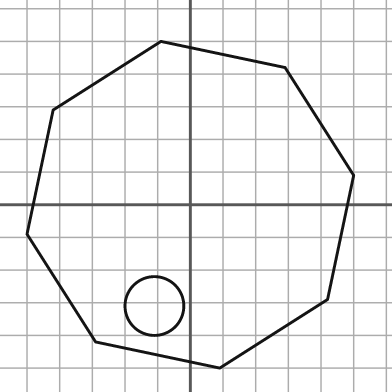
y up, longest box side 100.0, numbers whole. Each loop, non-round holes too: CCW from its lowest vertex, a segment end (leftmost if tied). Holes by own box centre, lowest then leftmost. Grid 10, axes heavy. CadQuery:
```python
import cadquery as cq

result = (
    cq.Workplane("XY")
    .moveTo(9.0, -50.0)
    .lineTo(42.0, -29.0)
    .lineTo(50.0, 9.0)
    .lineTo(29.0, 42.0)
    .lineTo(-9.0, 50.0)
    .lineTo(-42.0, 29.0)
    .lineTo(-50.0, -9.0)
    .lineTo(-29.0, -42.0)
    .close()
    .moveTo(-11.0, -31.0)
    .circle(9.0)
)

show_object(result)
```